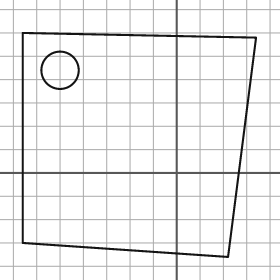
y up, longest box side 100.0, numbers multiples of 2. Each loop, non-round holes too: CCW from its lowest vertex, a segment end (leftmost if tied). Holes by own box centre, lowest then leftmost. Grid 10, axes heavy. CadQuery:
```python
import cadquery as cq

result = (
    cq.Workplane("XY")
    .moveTo(22.0, -36.0)
    .lineTo(34.0, 58.0)
    .lineTo(-66.0, 60.0)
    .lineTo(-66.0, -30.0)
    .close()
    .moveTo(-50.0, 44.0)
    .circle(8.0)
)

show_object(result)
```